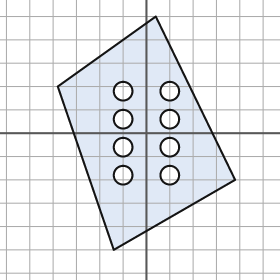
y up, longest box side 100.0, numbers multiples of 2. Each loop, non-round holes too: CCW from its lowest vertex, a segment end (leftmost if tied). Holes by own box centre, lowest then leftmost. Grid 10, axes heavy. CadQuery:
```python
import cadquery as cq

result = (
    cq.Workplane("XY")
    .moveTo(-14.0, -50.0)
    .lineTo(38.0, -20.0)
    .lineTo(4.0, 50.0)
    .lineTo(-38.0, 20.0)
    .close()
    .moveTo(-10.0, -18.0)
    .circle(4.0)
    .moveTo(10.0, -18.0)
    .circle(4.0)
    .moveTo(-10.0, -6.0)
    .circle(4.0)
    .moveTo(10.0, -6.0)
    .circle(4.0)
    .moveTo(-10.0, 6.0)
    .circle(4.0)
    .moveTo(10.0, 6.0)
    .circle(4.0)
    .moveTo(-10.0, 18.0)
    .circle(4.0)
    .moveTo(10.0, 18.0)
    .circle(4.0)
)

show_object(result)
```